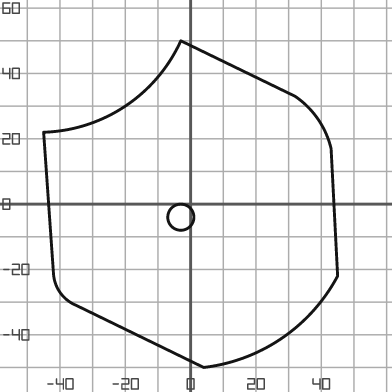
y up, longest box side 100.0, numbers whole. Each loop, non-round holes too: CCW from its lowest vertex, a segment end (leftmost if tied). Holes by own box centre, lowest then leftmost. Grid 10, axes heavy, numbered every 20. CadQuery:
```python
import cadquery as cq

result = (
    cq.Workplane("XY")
    .moveTo(4.0, -50.0)
    .threePointArc((28.0, -41.0), (45.0, -22.0))
    .lineTo(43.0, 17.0)
    .threePointArc((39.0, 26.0), (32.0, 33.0))
    .lineTo(-3.0, 50.0)
    .threePointArc((-20.0, 30.0), (-45.0, 22.0))
    .lineTo(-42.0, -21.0)
    .threePointArc((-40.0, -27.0), (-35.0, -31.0))
    .close()
    .moveTo(-3.0, -4.0)
    .circle(4.0)
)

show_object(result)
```